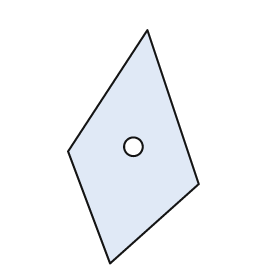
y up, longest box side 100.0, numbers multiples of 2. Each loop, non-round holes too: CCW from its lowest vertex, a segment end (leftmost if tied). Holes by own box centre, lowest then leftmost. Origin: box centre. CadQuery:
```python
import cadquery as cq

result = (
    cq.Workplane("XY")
    .moveTo(-10.0, -50.0)
    .lineTo(28.0, -16.0)
    .lineTo(6.0, 50.0)
    .lineTo(-28.0, -2.0)
    .close()
    .moveTo(0.0, 0.0)
    .circle(4.0)
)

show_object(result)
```